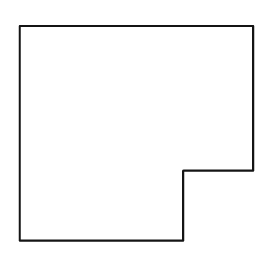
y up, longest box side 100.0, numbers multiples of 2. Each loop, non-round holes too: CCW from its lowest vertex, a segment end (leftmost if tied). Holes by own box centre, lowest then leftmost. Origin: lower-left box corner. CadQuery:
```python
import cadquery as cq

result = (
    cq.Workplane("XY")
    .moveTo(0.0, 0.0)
    .lineTo(70.0, 0.0)
    .lineTo(70.0, 30.0)
    .lineTo(100.0, 30.0)
    .lineTo(100.0, 92.0)
    .lineTo(0.0, 92.0)
    .close()
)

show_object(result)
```